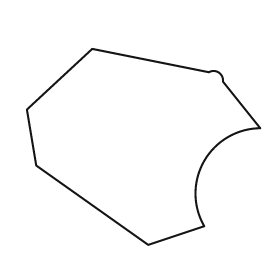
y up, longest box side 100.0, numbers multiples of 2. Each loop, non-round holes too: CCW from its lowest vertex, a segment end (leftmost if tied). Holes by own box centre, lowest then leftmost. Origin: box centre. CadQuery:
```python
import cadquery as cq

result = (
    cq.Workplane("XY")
    .moveTo(2.0, -42.0)
    .lineTo(26.0, -34.0)
    .threePointArc((26.0, -6.0), (50.0, 8.0))
    .lineTo(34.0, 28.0)
    .threePointArc((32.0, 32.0), (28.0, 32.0))
    .lineTo(-22.0, 42.0)
    .lineTo(-50.0, 16.0)
    .lineTo(-46.0, -8.0)
    .close()
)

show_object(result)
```